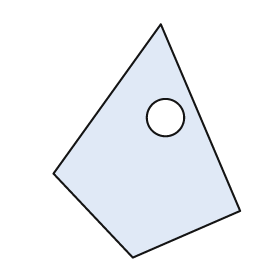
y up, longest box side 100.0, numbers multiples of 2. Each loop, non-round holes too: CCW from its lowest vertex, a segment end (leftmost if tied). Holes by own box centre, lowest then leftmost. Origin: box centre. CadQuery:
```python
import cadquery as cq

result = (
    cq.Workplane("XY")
    .moveTo(-6.0, -50.0)
    .lineTo(40.0, -30.0)
    .lineTo(6.0, 50.0)
    .lineTo(-40.0, -14.0)
    .close()
    .moveTo(8.0, 10.0)
    .circle(8.0)
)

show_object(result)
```